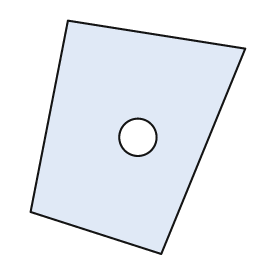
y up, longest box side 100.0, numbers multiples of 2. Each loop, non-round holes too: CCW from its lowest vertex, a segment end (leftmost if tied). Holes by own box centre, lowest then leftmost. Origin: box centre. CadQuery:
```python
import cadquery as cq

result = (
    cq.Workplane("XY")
    .moveTo(10.0, -50.0)
    .lineTo(46.0, 38.0)
    .lineTo(-30.0, 50.0)
    .lineTo(-46.0, -32.0)
    .close()
    .moveTo(0.0, 0.0)
    .circle(8.0)
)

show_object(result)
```